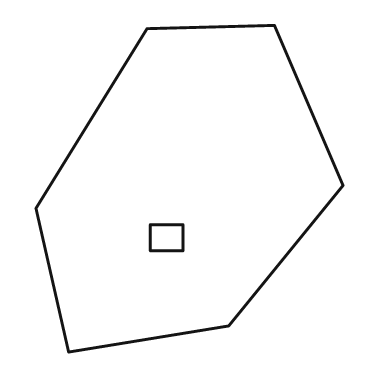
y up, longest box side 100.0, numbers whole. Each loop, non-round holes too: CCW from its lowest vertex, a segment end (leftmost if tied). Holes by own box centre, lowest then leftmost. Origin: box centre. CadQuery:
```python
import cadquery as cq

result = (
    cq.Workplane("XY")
    .moveTo(-37.0, -50.0)
    .lineTo(12.0, -42.0)
    .lineTo(47.0, 1.0)
    .lineTo(26.0, 50.0)
    .lineTo(-13.0, 49.0)
    .lineTo(-47.0, -6.0)
    .close()
    .moveTo(-12.0, -19.0)
    .lineTo(-2.0, -19.0)
    .lineTo(-2.0, -11.0)
    .lineTo(-12.0, -11.0)
    .close()
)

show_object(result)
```